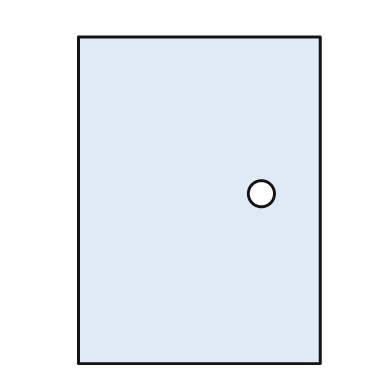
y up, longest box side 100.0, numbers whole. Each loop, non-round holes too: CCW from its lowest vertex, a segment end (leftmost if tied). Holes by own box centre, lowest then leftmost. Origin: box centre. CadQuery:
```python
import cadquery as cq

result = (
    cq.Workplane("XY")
    .moveTo(-37.0, -50.0)
    .lineTo(37.0, -50.0)
    .lineTo(37.0, 50.0)
    .lineTo(-37.0, 50.0)
    .close()
    .moveTo(19.0, 2.0)
    .circle(4.0)
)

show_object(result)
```